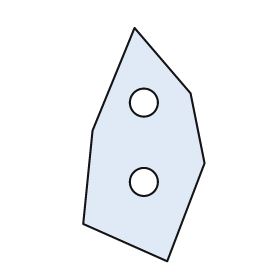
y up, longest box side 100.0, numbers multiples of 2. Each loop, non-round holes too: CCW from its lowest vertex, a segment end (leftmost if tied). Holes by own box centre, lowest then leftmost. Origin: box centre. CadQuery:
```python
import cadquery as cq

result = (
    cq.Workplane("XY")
    .moveTo(10.0, -50.0)
    .lineTo(26.0, -8.0)
    .lineTo(20.0, 22.0)
    .lineTo(-4.0, 50.0)
    .lineTo(-22.0, 6.0)
    .lineTo(-26.0, -34.0)
    .close()
    .moveTo(0.0, -16.0)
    .circle(6.0)
    .moveTo(0.0, 18.0)
    .circle(6.0)
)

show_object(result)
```